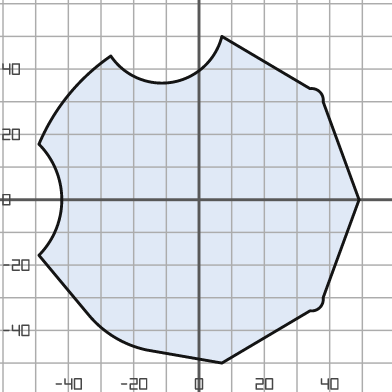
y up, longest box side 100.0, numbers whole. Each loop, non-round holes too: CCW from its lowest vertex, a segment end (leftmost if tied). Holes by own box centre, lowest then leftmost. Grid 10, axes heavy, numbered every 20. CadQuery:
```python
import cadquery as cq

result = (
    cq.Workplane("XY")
    .moveTo(7.0, -50.0)
    .lineTo(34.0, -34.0)
    .threePointArc((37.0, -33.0), (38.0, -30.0))
    .lineTo(49.0, 0.0)
    .lineTo(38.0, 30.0)
    .threePointArc((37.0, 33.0), (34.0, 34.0))
    .lineTo(7.0, 50.0)
    .threePointArc((-8.0, 36.0), (-27.0, 44.0))
    .threePointArc((-40.0, 32.0), (-49.0, 17.0))
    .threePointArc((-42.0, 0.0), (-49.0, -17.0))
    .lineTo(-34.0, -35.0)
    .threePointArc((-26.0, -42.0), (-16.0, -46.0))
    .close()
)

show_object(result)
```